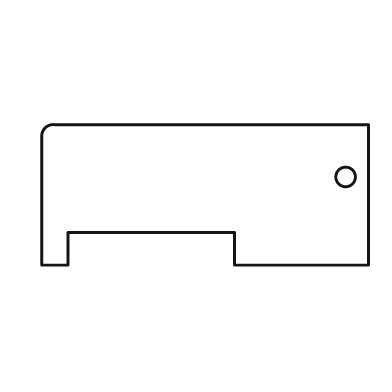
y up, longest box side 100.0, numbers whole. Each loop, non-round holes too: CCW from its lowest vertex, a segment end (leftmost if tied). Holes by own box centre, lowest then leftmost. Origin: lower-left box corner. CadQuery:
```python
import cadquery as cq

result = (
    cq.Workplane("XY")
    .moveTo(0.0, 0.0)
    .lineTo(8.0, 0.0)
    .lineTo(8.0, 10.0)
    .lineTo(59.0, 10.0)
    .lineTo(59.0, 0.0)
    .lineTo(100.0, 0.0)
    .lineTo(100.0, 43.0)
    .lineTo(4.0, 43.0)
    .threePointArc((1.0, 42.0), (0.0, 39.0))
    .close()
    .moveTo(93.0, 27.0)
    .circle(3.0)
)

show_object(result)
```